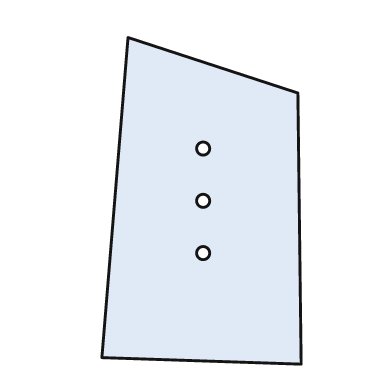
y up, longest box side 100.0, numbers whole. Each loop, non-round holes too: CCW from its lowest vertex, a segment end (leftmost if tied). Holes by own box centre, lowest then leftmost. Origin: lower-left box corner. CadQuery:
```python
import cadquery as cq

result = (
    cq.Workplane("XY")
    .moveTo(61.0, 0.0)
    .lineTo(60.0, 83.0)
    .lineTo(8.0, 100.0)
    .lineTo(0.0, 2.0)
    .close()
    .moveTo(31.0, 34.0)
    .circle(2.0)
    .moveTo(31.0, 50.0)
    .circle(2.0)
    .moveTo(31.0, 66.0)
    .circle(2.0)
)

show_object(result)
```